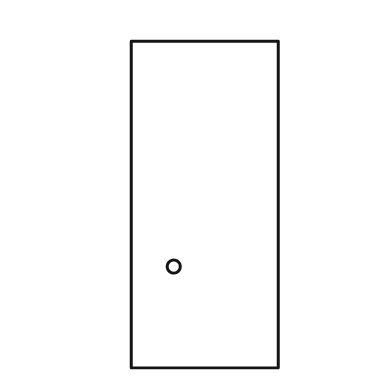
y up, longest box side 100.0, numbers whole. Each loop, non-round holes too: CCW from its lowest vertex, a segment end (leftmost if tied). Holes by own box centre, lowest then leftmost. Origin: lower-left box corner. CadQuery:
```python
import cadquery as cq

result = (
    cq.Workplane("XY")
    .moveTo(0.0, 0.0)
    .lineTo(45.0, 0.0)
    .lineTo(45.0, 100.0)
    .lineTo(0.0, 100.0)
    .close()
    .moveTo(13.0, 31.0)
    .circle(2.0)
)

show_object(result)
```